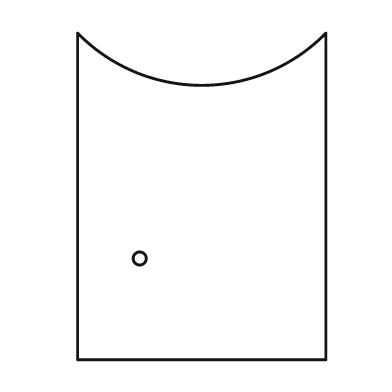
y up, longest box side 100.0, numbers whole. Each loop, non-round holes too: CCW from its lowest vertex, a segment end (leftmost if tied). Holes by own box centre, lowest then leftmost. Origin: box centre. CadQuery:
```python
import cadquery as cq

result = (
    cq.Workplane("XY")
    .moveTo(-38.0, -50.0)
    .lineTo(38.0, -50.0)
    .lineTo(38.0, 50.0)
    .threePointArc((0.0, 34.0), (-38.0, 50.0))
    .close()
    .moveTo(-19.0, -19.0)
    .circle(2.0)
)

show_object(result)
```